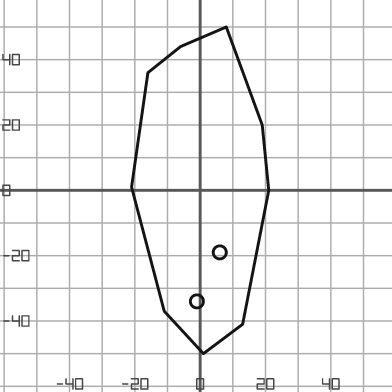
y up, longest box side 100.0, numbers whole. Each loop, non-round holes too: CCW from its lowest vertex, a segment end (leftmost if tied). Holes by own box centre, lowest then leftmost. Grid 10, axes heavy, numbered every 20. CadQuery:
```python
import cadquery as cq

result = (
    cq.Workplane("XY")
    .moveTo(1.0, -50.0)
    .lineTo(13.0, -41.0)
    .lineTo(21.0, 0.0)
    .lineTo(19.0, 20.0)
    .lineTo(8.0, 50.0)
    .lineTo(-6.0, 44.0)
    .lineTo(-16.0, 36.0)
    .lineTo(-21.0, 1.0)
    .lineTo(-11.0, -37.0)
    .close()
    .moveTo(-1.0, -34.0)
    .circle(2.0)
    .moveTo(6.0, -19.0)
    .circle(2.0)
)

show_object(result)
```